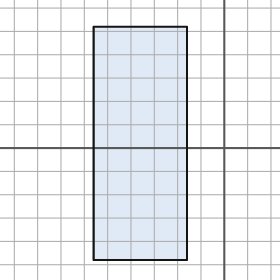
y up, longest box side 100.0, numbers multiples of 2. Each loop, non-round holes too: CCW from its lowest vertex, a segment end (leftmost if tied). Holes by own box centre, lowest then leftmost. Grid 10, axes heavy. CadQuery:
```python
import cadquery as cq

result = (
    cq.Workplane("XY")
    .moveTo(-56.0, -48.0)
    .lineTo(-16.0, -48.0)
    .lineTo(-16.0, 52.0)
    .lineTo(-56.0, 52.0)
    .close()
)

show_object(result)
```